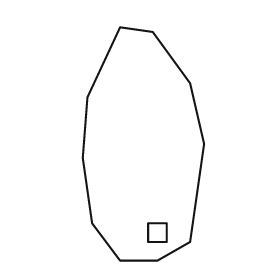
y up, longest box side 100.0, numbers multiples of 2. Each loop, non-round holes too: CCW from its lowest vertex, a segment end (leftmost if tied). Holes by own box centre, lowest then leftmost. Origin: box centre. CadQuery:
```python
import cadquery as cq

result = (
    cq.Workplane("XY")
    .moveTo(-10.0, -50.0)
    .lineTo(6.0, -50.0)
    .lineTo(20.0, -42.0)
    .lineTo(26.0, 0.0)
    .lineTo(20.0, 26.0)
    .lineTo(4.0, 48.0)
    .lineTo(-10.0, 50.0)
    .lineTo(-24.0, 20.0)
    .lineTo(-26.0, -6.0)
    .lineTo(-22.0, -34.0)
    .close()
    .moveTo(2.0, -42.0)
    .lineTo(10.0, -42.0)
    .lineTo(10.0, -34.0)
    .lineTo(2.0, -34.0)
    .close()
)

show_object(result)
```